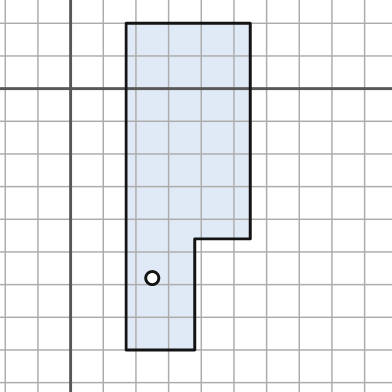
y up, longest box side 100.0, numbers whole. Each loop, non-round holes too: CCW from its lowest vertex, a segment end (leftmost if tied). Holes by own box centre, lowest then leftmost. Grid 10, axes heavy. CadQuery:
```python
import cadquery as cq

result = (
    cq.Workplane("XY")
    .moveTo(17.0, -80.0)
    .lineTo(38.0, -80.0)
    .lineTo(38.0, -46.0)
    .lineTo(55.0, -46.0)
    .lineTo(55.0, 20.0)
    .lineTo(17.0, 20.0)
    .close()
    .moveTo(25.0, -58.0)
    .circle(2.0)
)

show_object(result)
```